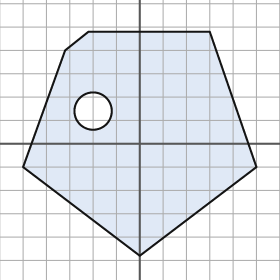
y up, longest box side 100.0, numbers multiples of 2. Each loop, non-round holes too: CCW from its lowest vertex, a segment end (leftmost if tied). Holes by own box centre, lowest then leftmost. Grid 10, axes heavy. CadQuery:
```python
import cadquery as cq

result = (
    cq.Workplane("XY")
    .moveTo(0.0, -48.0)
    .lineTo(50.0, -10.0)
    .lineTo(30.0, 48.0)
    .lineTo(-22.0, 48.0)
    .lineTo(-32.0, 40.0)
    .lineTo(-50.0, -10.0)
    .close()
    .moveTo(-20.0, 14.0)
    .circle(8.0)
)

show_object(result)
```